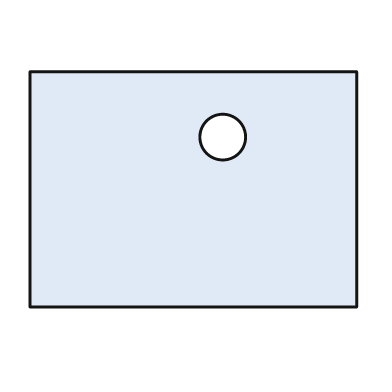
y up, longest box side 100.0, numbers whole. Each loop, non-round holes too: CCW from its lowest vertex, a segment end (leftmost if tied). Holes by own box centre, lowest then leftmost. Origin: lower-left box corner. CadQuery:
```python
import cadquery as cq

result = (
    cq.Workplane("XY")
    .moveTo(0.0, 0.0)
    .lineTo(100.0, 0.0)
    .lineTo(100.0, 72.0)
    .lineTo(0.0, 72.0)
    .close()
    .moveTo(59.0, 52.0)
    .circle(7.0)
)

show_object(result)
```